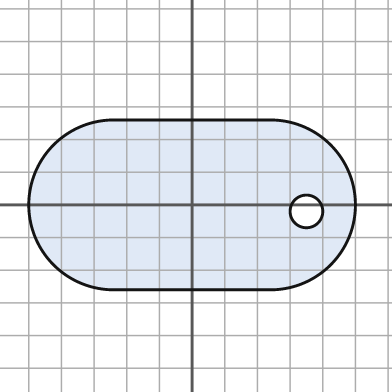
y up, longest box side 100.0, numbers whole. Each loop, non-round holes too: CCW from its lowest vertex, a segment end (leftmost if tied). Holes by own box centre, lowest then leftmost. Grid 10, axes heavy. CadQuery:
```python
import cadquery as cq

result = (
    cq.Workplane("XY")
    .moveTo(-24.0, -26.0)
    .lineTo(24.0, -26.0)
    .threePointArc((50.0, 0.0), (24.0, 26.0))
    .lineTo(-24.0, 26.0)
    .threePointArc((-50.0, 0.0), (-24.0, -26.0))
    .close()
    .moveTo(35.0, -2.0)
    .circle(5.0)
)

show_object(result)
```